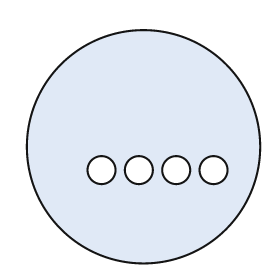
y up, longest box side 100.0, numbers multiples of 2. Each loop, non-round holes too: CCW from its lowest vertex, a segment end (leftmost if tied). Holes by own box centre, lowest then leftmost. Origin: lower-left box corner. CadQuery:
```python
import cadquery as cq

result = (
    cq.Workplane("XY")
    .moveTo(50.0, 50.0)
    .circle(50.0)
    .moveTo(32.0, 40.0)
    .circle(6.0)
    .moveTo(48.0, 40.0)
    .circle(6.0)
    .moveTo(64.0, 40.0)
    .circle(6.0)
    .moveTo(80.0, 40.0)
    .circle(6.0)
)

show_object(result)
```